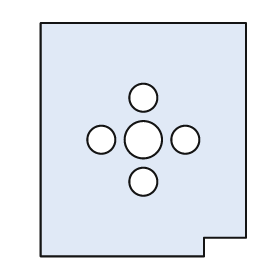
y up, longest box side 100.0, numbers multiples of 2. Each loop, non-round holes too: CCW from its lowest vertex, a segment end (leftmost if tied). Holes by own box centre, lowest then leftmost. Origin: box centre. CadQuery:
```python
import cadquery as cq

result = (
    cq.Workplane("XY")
    .moveTo(-44.0, -50.0)
    .lineTo(26.0, -50.0)
    .lineTo(26.0, -42.0)
    .lineTo(44.0, -42.0)
    .lineTo(44.0, 50.0)
    .lineTo(-44.0, 50.0)
    .close()
    .moveTo(0.0, -18.0)
    .circle(6.0)
    .moveTo(-18.0, 0.0)
    .circle(6.0)
    .moveTo(0.0, 0.0)
    .circle(8.0)
    .moveTo(18.0, 0.0)
    .circle(6.0)
    .moveTo(0.0, 18.0)
    .circle(6.0)
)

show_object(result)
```